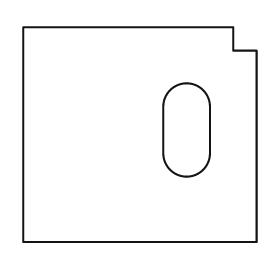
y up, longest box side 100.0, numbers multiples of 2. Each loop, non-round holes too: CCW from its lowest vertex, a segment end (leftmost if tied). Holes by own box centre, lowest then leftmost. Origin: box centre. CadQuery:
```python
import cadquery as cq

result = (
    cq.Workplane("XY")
    .moveTo(-50.0, -46.0)
    .lineTo(50.0, -46.0)
    .lineTo(50.0, 36.0)
    .lineTo(40.0, 36.0)
    .lineTo(40.0, 46.0)
    .lineTo(-50.0, 46.0)
    .close()
    .moveTo(10.0, -8.0)
    .threePointArc((20.0, -18.0), (30.0, -8.0))
    .lineTo(30.0, 12.0)
    .threePointArc((20.0, 22.0), (10.0, 12.0))
    .close()
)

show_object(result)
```